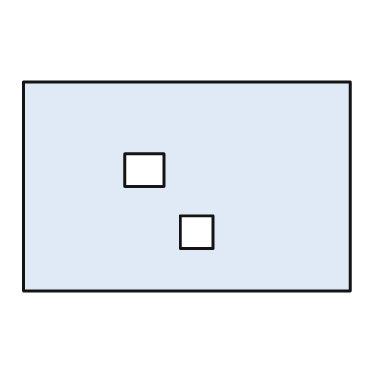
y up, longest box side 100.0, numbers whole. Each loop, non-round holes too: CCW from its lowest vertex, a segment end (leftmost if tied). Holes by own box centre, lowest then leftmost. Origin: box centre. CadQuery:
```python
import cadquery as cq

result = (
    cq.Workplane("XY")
    .moveTo(-50.0, -32.0)
    .lineTo(50.0, -32.0)
    .lineTo(50.0, 32.0)
    .lineTo(-50.0, 32.0)
    .close()
    .moveTo(-2.0, -19.0)
    .lineTo(8.0, -19.0)
    .lineTo(8.0, -9.0)
    .lineTo(-2.0, -9.0)
    .close()
    .moveTo(-19.0, 0.0)
    .lineTo(-7.0, 0.0)
    .lineTo(-7.0, 10.0)
    .lineTo(-19.0, 10.0)
    .close()
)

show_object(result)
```